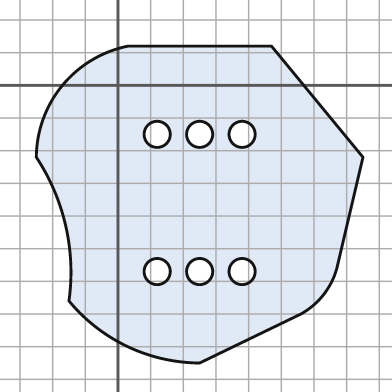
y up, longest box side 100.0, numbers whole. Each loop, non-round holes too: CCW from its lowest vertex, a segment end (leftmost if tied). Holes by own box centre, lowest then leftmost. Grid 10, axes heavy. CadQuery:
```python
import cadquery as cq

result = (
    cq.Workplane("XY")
    .moveTo(25.0, -85.0)
    .lineTo(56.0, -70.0)
    .threePointArc((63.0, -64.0), (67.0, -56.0))
    .lineTo(75.0, -22.0)
    .lineTo(47.0, 12.0)
    .lineTo(3.0, 12.0)
    .threePointArc((-17.0, 0.0), (-25.0, -22.0))
    .threePointArc((-16.0, -43.0), (-15.0, -66.0))
    .threePointArc((3.0, -80.0), (25.0, -85.0))
    .close()
    .moveTo(12.0, -57.0)
    .circle(4.0)
    .moveTo(25.0, -57.0)
    .circle(4.0)
    .moveTo(38.0, -57.0)
    .circle(4.0)
    .moveTo(12.0, -15.0)
    .circle(4.0)
    .moveTo(25.0, -15.0)
    .circle(4.0)
    .moveTo(38.0, -15.0)
    .circle(4.0)
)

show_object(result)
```